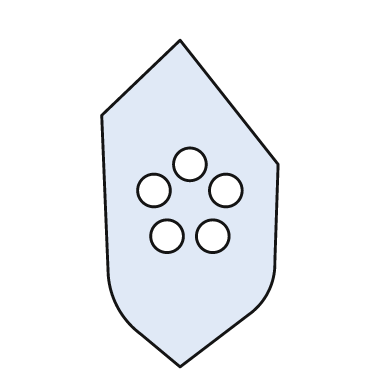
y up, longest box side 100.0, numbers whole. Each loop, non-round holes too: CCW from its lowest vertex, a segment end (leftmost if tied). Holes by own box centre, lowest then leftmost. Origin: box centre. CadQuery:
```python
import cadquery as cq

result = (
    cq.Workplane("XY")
    .moveTo(-3.0, -50.0)
    .lineTo(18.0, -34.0)
    .threePointArc((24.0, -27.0), (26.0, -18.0))
    .lineTo(27.0, 12.0)
    .lineTo(-3.0, 50.0)
    .lineTo(-27.0, 27.0)
    .lineTo(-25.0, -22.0)
    .threePointArc((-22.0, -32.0), (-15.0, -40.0))
    .close()
    .moveTo(-7.0, -10.0)
    .circle(5.0)
    .moveTo(7.0, -10.0)
    .circle(5.0)
    .moveTo(-11.0, 4.0)
    .circle(5.0)
    .moveTo(11.0, 4.0)
    .circle(5.0)
    .moveTo(0.0, 12.0)
    .circle(5.0)
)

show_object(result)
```